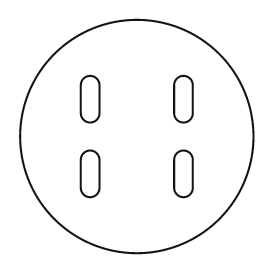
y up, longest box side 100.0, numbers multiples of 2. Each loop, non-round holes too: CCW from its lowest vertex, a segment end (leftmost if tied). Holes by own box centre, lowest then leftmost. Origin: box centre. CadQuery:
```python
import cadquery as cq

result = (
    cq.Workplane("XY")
    .moveTo(0.0, 0.0)
    .circle(50.0)
    .moveTo(-24.0, -22.0)
    .threePointArc((-20.0, -26.0), (-16.0, -22.0))
    .lineTo(-16.0, -10.0)
    .threePointArc((-20.0, -6.0), (-24.0, -10.0))
    .close()
    .moveTo(16.0, -22.0)
    .threePointArc((20.0, -26.0), (24.0, -22.0))
    .lineTo(24.0, -10.0)
    .threePointArc((20.0, -6.0), (16.0, -10.0))
    .close()
    .moveTo(-24.0, 10.0)
    .threePointArc((-20.0, 6.0), (-16.0, 10.0))
    .lineTo(-16.0, 22.0)
    .threePointArc((-20.0, 26.0), (-24.0, 22.0))
    .close()
    .moveTo(16.0, 10.0)
    .threePointArc((20.0, 6.0), (24.0, 10.0))
    .lineTo(24.0, 22.0)
    .threePointArc((20.0, 26.0), (16.0, 22.0))
    .close()
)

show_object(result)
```